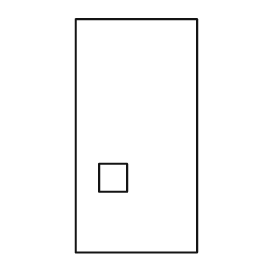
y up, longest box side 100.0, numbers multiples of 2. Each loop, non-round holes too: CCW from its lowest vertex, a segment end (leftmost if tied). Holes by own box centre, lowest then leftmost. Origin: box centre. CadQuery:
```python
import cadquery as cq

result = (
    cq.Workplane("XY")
    .moveTo(-26.0, -50.0)
    .lineTo(26.0, -50.0)
    .lineTo(26.0, 50.0)
    .lineTo(-26.0, 50.0)
    .close()
    .moveTo(-16.0, -24.0)
    .lineTo(-4.0, -24.0)
    .lineTo(-4.0, -12.0)
    .lineTo(-16.0, -12.0)
    .close()
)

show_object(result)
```